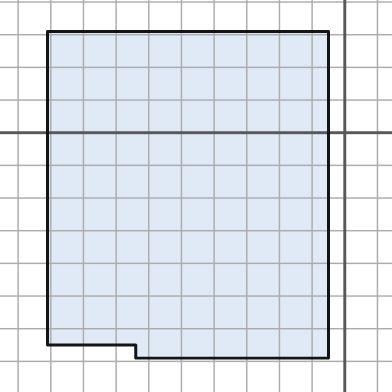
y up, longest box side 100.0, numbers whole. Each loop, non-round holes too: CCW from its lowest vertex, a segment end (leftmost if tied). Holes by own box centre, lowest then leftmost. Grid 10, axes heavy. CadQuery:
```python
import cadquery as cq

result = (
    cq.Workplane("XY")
    .moveTo(-64.0, -69.0)
    .lineTo(-5.0, -69.0)
    .lineTo(-5.0, 31.0)
    .lineTo(-91.0, 31.0)
    .lineTo(-91.0, -65.0)
    .lineTo(-64.0, -65.0)
    .close()
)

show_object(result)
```